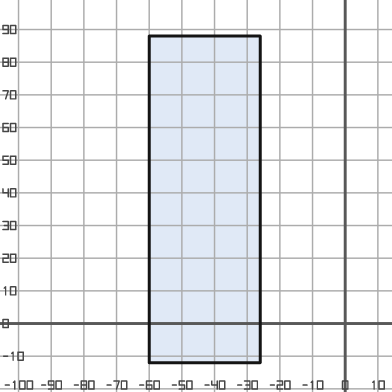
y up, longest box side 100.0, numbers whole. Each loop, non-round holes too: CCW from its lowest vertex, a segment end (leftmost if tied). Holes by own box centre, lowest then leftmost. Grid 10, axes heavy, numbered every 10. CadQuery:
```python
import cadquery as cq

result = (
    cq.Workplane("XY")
    .moveTo(-60.0, -12.0)
    .lineTo(-26.0, -12.0)
    .lineTo(-26.0, 88.0)
    .lineTo(-60.0, 88.0)
    .close()
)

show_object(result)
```